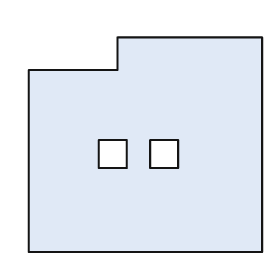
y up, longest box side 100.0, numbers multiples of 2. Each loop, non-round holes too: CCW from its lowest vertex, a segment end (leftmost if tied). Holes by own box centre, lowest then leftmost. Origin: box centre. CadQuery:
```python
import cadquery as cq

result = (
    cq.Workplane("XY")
    .moveTo(-50.0, -46.0)
    .lineTo(50.0, -46.0)
    .lineTo(50.0, 46.0)
    .lineTo(-12.0, 46.0)
    .lineTo(-12.0, 32.0)
    .lineTo(-50.0, 32.0)
    .close()
    .moveTo(-20.0, -10.0)
    .lineTo(-8.0, -10.0)
    .lineTo(-8.0, 2.0)
    .lineTo(-20.0, 2.0)
    .close()
    .moveTo(2.0, -10.0)
    .lineTo(14.0, -10.0)
    .lineTo(14.0, 2.0)
    .lineTo(2.0, 2.0)
    .close()
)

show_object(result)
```